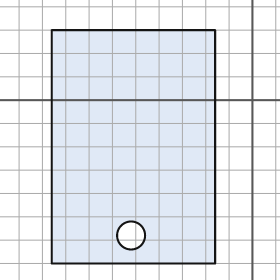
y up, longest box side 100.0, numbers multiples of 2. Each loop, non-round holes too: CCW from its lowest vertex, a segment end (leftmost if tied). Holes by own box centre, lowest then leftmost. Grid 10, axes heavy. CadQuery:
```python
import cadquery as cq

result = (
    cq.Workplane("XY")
    .moveTo(-86.0, -70.0)
    .lineTo(-16.0, -70.0)
    .lineTo(-16.0, 30.0)
    .lineTo(-86.0, 30.0)
    .close()
    .moveTo(-52.0, -58.0)
    .circle(6.0)
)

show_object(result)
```